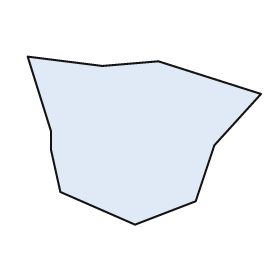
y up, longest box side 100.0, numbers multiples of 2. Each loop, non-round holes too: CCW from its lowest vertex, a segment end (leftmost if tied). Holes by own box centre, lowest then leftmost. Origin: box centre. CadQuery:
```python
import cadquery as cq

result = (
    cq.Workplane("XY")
    .moveTo(-4.0, -36.0)
    .lineTo(22.0, -26.0)
    .lineTo(30.0, -2.0)
    .lineTo(50.0, 20.0)
    .lineTo(6.0, 34.0)
    .lineTo(-18.0, 32.0)
    .lineTo(-50.0, 36.0)
    .lineTo(-40.0, 4.0)
    .lineTo(-40.0, -4.0)
    .lineTo(-36.0, -22.0)
    .close()
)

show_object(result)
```